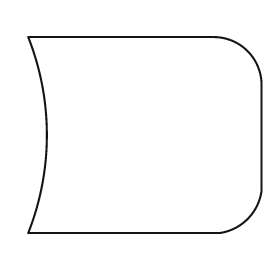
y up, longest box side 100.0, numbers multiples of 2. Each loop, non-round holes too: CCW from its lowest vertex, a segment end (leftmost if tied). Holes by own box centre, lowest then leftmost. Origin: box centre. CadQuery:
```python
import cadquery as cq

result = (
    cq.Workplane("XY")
    .moveTo(-50.0, -42.0)
    .lineTo(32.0, -42.0)
    .threePointArc((44.0, -36.0), (50.0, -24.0))
    .lineTo(50.0, 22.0)
    .threePointArc((44.0, 36.0), (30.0, 42.0))
    .lineTo(-50.0, 42.0)
    .threePointArc((-42.0, 0.0), (-50.0, -42.0))
    .close()
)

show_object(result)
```